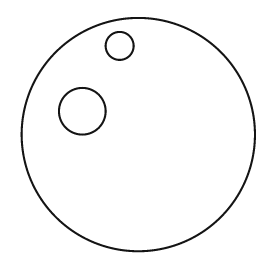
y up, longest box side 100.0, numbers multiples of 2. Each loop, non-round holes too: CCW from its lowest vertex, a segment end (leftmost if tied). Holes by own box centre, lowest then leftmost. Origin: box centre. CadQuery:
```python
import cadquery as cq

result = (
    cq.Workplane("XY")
    .moveTo(0.0, 0.0)
    .circle(50.0)
    .moveTo(-24.0, 10.0)
    .circle(10.0)
    .moveTo(-8.0, 38.0)
    .circle(6.0)
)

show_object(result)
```